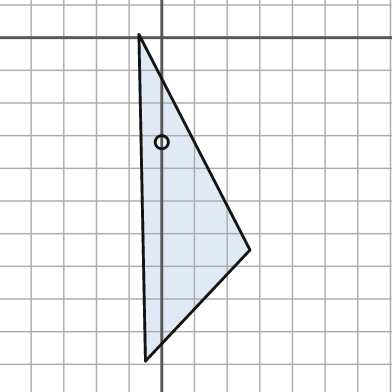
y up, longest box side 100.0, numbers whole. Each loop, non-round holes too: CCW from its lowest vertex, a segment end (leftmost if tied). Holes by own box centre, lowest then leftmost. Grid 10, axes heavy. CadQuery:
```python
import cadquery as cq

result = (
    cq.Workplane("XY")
    .moveTo(-5.0, -99.0)
    .lineTo(27.0, -65.0)
    .lineTo(-7.0, 1.0)
    .close()
    .moveTo(0.0, -32.0)
    .circle(2.0)
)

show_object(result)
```